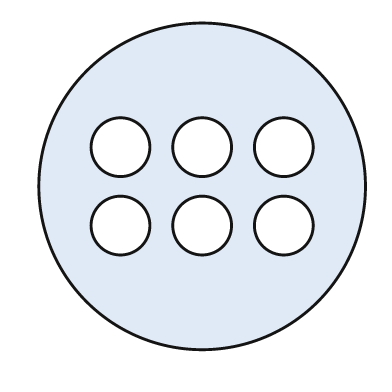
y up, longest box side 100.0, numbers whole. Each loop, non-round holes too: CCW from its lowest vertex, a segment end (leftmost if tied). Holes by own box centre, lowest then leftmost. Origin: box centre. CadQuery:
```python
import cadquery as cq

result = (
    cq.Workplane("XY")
    .moveTo(0.0, 0.0)
    .circle(50.0)
    .moveTo(-25.0, -12.0)
    .circle(9.0)
    .moveTo(0.0, -12.0)
    .circle(9.0)
    .moveTo(25.0, -12.0)
    .circle(9.0)
    .moveTo(-25.0, 12.0)
    .circle(9.0)
    .moveTo(0.0, 12.0)
    .circle(9.0)
    .moveTo(25.0, 12.0)
    .circle(9.0)
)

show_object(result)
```